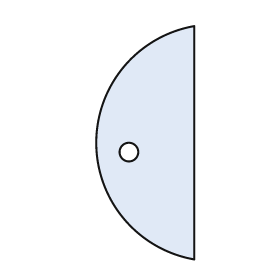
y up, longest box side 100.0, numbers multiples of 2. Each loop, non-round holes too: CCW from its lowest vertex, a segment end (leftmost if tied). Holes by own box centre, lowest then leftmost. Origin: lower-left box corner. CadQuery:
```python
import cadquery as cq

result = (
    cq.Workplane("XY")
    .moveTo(42.0, 0.0)
    .lineTo(42.0, 100.0)
    .threePointArc((0.0, 50.0), (42.0, 0.0))
    .close()
    .moveTo(14.0, 46.0)
    .circle(4.0)
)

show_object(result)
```